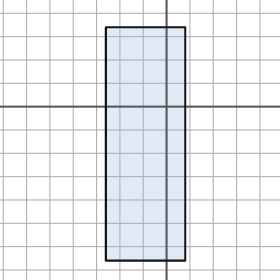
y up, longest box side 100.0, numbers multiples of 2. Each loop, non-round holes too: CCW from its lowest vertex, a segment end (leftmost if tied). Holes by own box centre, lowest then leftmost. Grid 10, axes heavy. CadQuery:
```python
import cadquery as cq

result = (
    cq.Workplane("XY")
    .moveTo(-26.0, -66.0)
    .lineTo(8.0, -66.0)
    .lineTo(8.0, 34.0)
    .lineTo(-26.0, 34.0)
    .close()
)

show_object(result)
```